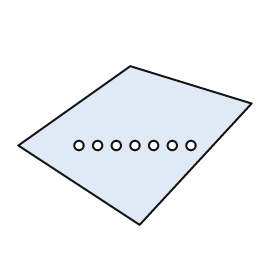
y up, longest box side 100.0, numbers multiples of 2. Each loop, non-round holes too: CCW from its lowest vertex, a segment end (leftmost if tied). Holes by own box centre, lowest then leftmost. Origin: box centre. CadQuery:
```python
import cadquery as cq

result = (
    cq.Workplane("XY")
    .moveTo(2.0, -34.0)
    .lineTo(50.0, 18.0)
    .lineTo(-2.0, 34.0)
    .lineTo(-50.0, 0.0)
    .close()
    .moveTo(-24.0, 0.0)
    .circle(2.0)
    .moveTo(-16.0, 0.0)
    .circle(2.0)
    .moveTo(-8.0, 0.0)
    .circle(2.0)
    .moveTo(0.0, 0.0)
    .circle(2.0)
    .moveTo(8.0, 0.0)
    .circle(2.0)
    .moveTo(16.0, 0.0)
    .circle(2.0)
    .moveTo(24.0, 0.0)
    .circle(2.0)
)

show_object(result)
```